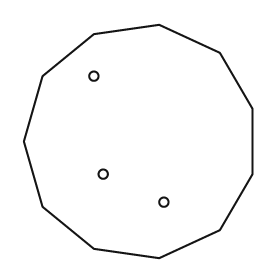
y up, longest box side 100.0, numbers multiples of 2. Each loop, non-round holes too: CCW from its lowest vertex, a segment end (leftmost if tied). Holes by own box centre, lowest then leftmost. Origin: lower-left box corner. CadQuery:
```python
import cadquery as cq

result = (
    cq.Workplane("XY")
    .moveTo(58.0, 0.0)
    .lineTo(84.0, 12.0)
    .lineTo(98.0, 36.0)
    .lineTo(98.0, 64.0)
    .lineTo(84.0, 88.0)
    .lineTo(58.0, 100.0)
    .lineTo(30.0, 96.0)
    .lineTo(8.0, 78.0)
    .lineTo(0.0, 50.0)
    .lineTo(8.0, 22.0)
    .lineTo(30.0, 4.0)
    .close()
    .moveTo(60.0, 24.0)
    .circle(2.0)
    .moveTo(34.0, 36.0)
    .circle(2.0)
    .moveTo(30.0, 78.0)
    .circle(2.0)
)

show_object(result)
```